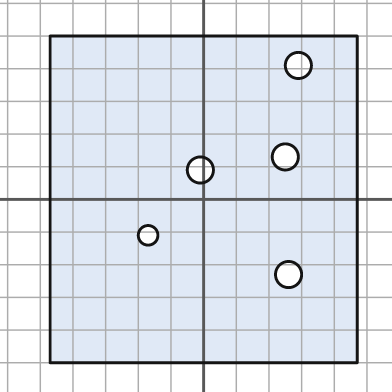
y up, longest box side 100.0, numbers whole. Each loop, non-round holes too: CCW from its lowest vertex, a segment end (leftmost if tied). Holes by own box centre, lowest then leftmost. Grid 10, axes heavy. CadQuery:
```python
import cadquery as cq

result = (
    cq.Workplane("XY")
    .moveTo(-47.0, -50.0)
    .lineTo(47.0, -50.0)
    .lineTo(47.0, 50.0)
    .lineTo(-47.0, 50.0)
    .close()
    .moveTo(26.0, -23.0)
    .circle(4.0)
    .moveTo(-17.0, -11.0)
    .circle(3.0)
    .moveTo(-1.0, 9.0)
    .circle(4.0)
    .moveTo(25.0, 13.0)
    .circle(4.0)
    .moveTo(29.0, 41.0)
    .circle(4.0)
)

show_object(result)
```